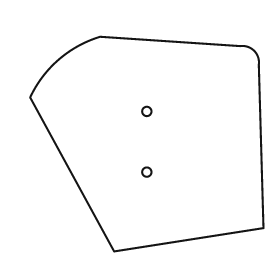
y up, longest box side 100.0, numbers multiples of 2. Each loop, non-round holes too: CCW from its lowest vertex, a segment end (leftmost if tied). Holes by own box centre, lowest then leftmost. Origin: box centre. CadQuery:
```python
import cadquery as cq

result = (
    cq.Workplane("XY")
    .moveTo(-14.0, -46.0)
    .lineTo(50.0, -36.0)
    .lineTo(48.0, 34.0)
    .threePointArc((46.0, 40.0), (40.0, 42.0))
    .lineTo(-20.0, 46.0)
    .threePointArc((-38.0, 36.0), (-50.0, 20.0))
    .close()
    .moveTo(0.0, -12.0)
    .circle(2.0)
    .moveTo(0.0, 14.0)
    .circle(2.0)
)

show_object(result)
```